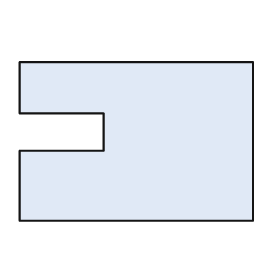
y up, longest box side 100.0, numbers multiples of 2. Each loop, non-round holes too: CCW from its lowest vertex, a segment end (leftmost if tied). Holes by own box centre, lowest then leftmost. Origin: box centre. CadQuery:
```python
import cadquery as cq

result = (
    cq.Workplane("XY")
    .moveTo(-50.0, -34.0)
    .lineTo(50.0, -34.0)
    .lineTo(50.0, 34.0)
    .lineTo(-50.0, 34.0)
    .lineTo(-50.0, 12.0)
    .lineTo(-14.0, 12.0)
    .lineTo(-14.0, -4.0)
    .lineTo(-50.0, -4.0)
    .close()
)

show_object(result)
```